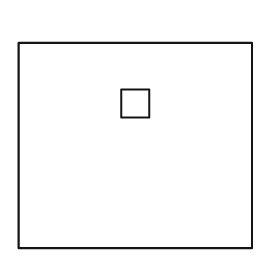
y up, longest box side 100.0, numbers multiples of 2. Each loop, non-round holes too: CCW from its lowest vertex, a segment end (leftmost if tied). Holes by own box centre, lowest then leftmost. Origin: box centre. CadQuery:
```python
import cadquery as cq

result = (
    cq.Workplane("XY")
    .moveTo(-50.0, -44.0)
    .lineTo(50.0, -44.0)
    .lineTo(50.0, 44.0)
    .lineTo(-50.0, 44.0)
    .close()
    .moveTo(-6.0, 12.0)
    .lineTo(6.0, 12.0)
    .lineTo(6.0, 24.0)
    .lineTo(-6.0, 24.0)
    .close()
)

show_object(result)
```